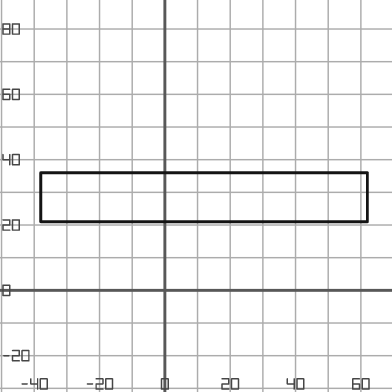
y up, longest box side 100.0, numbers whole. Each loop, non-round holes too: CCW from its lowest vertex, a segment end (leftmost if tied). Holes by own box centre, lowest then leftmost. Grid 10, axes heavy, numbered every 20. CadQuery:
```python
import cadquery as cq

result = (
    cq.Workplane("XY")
    .moveTo(-38.0, 21.0)
    .lineTo(62.0, 21.0)
    .lineTo(62.0, 36.0)
    .lineTo(-38.0, 36.0)
    .close()
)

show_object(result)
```